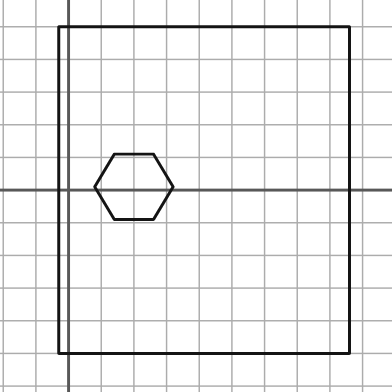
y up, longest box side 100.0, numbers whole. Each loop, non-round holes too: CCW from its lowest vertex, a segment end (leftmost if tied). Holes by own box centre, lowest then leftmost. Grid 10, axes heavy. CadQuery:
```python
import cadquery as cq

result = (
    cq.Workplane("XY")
    .moveTo(-3.0, -50.0)
    .lineTo(86.0, -50.0)
    .lineTo(86.0, 50.0)
    .lineTo(-3.0, 50.0)
    .close()
    .moveTo(14.0, -9.0)
    .lineTo(26.0, -9.0)
    .lineTo(32.0, 1.0)
    .lineTo(26.0, 11.0)
    .lineTo(14.0, 11.0)
    .lineTo(8.0, 1.0)
    .close()
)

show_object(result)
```